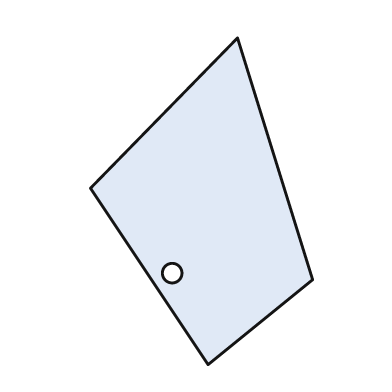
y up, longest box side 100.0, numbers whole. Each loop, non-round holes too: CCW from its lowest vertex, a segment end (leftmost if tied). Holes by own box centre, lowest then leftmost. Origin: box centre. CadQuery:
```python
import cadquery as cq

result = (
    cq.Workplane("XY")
    .moveTo(2.0, -50.0)
    .lineTo(34.0, -24.0)
    .lineTo(11.0, 50.0)
    .lineTo(-34.0, 4.0)
    .close()
    .moveTo(-9.0, -22.0)
    .circle(3.0)
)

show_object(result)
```